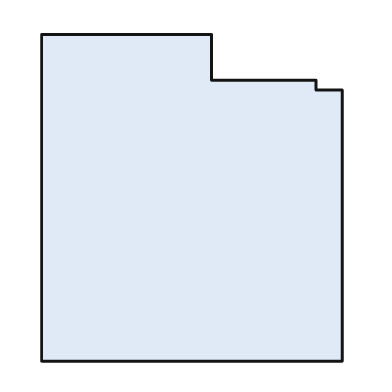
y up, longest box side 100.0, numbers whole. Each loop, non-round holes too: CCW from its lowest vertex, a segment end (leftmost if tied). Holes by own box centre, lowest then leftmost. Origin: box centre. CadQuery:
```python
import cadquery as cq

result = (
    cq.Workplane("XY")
    .moveTo(-46.0, -50.0)
    .lineTo(46.0, -50.0)
    .lineTo(46.0, 33.0)
    .lineTo(38.0, 33.0)
    .lineTo(38.0, 36.0)
    .lineTo(6.0, 36.0)
    .lineTo(6.0, 50.0)
    .lineTo(-46.0, 50.0)
    .close()
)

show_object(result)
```